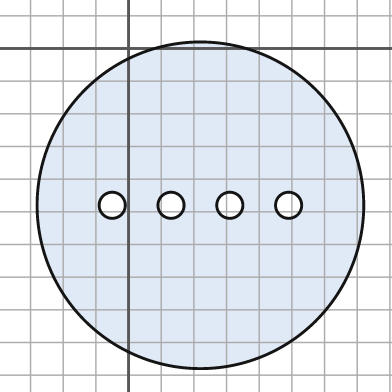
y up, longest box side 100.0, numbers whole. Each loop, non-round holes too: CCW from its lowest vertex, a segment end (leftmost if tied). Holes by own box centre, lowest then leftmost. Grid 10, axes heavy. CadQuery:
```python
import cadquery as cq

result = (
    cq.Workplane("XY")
    .moveTo(22.0, -48.0)
    .circle(50.0)
    .moveTo(-5.0, -48.0)
    .circle(4.0)
    .moveTo(13.0, -48.0)
    .circle(4.0)
    .moveTo(31.0, -48.0)
    .circle(4.0)
    .moveTo(49.0, -48.0)
    .circle(4.0)
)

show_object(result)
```